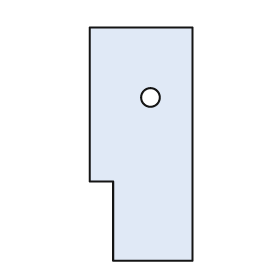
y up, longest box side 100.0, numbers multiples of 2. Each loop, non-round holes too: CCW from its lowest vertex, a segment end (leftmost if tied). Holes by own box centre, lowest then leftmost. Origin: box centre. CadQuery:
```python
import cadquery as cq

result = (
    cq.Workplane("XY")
    .moveTo(-12.0, -50.0)
    .lineTo(22.0, -50.0)
    .lineTo(22.0, 50.0)
    .lineTo(-22.0, 50.0)
    .lineTo(-22.0, -16.0)
    .lineTo(-12.0, -16.0)
    .close()
    .moveTo(4.0, 20.0)
    .circle(4.0)
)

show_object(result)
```